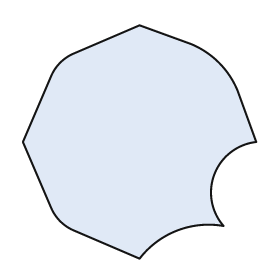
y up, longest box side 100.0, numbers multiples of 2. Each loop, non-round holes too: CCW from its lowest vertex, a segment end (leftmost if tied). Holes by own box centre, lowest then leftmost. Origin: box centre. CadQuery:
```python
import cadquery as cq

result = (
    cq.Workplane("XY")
    .moveTo(0.0, -50.0)
    .threePointArc((16.0, -38.0), (36.0, -36.0))
    .threePointArc((32.0, -14.0), (50.0, 0.0))
    .lineTo(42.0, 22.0)
    .threePointArc((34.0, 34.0), (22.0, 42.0))
    .lineTo(0.0, 50.0)
    .lineTo(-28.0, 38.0)
    .threePointArc((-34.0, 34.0), (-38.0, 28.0))
    .lineTo(-50.0, 0.0)
    .lineTo(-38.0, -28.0)
    .threePointArc((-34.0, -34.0), (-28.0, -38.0))
    .close()
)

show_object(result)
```